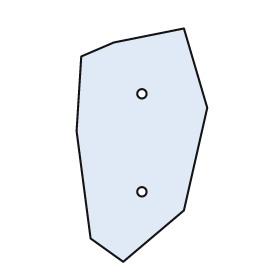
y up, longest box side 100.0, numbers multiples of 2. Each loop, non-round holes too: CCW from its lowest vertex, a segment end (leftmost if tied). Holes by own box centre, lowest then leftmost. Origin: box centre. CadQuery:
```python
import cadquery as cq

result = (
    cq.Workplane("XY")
    .moveTo(-8.0, -50.0)
    .lineTo(18.0, -28.0)
    .lineTo(28.0, 16.0)
    .lineTo(18.0, 50.0)
    .lineTo(-12.0, 44.0)
    .lineTo(-26.0, 38.0)
    .lineTo(-28.0, 6.0)
    .lineTo(-22.0, -40.0)
    .close()
    .moveTo(0.0, -20.0)
    .circle(2.0)
    .moveTo(0.0, 22.0)
    .circle(2.0)
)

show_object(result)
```